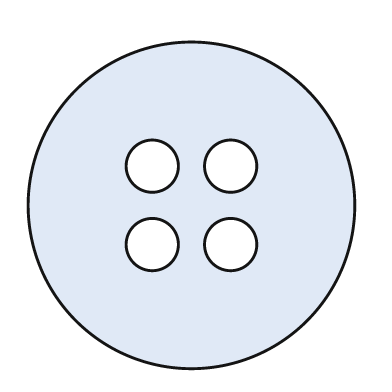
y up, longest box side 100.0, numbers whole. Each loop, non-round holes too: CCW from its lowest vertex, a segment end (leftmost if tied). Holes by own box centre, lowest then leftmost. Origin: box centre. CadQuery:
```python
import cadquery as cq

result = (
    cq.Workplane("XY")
    .moveTo(0.0, 0.0)
    .circle(50.0)
    .moveTo(-12.0, -12.0)
    .circle(8.0)
    .moveTo(12.0, -12.0)
    .circle(8.0)
    .moveTo(-12.0, 12.0)
    .circle(8.0)
    .moveTo(12.0, 12.0)
    .circle(8.0)
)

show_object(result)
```